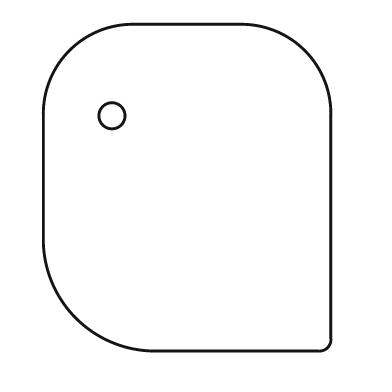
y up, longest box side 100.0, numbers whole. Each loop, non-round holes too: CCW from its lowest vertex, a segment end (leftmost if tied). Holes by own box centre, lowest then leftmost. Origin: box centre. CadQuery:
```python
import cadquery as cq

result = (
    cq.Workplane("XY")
    .moveTo(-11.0, -50.0)
    .lineTo(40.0, -50.0)
    .threePointArc((43.0, -49.0), (44.0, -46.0))
    .lineTo(44.0, 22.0)
    .threePointArc((36.0, 42.0), (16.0, 50.0))
    .lineTo(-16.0, 50.0)
    .threePointArc((-36.0, 42.0), (-44.0, 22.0))
    .lineTo(-44.0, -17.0)
    .threePointArc((-34.0, -40.0), (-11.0, -50.0))
    .close()
    .moveTo(-23.0, 22.0)
    .circle(4.0)
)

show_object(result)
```